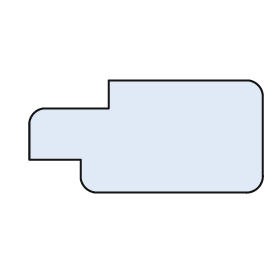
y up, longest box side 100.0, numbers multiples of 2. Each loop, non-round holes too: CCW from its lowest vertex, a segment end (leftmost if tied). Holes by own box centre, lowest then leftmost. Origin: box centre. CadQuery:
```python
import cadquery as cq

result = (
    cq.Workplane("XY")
    .moveTo(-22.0, -24.0)
    .lineTo(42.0, -24.0)
    .threePointArc((48.0, -22.0), (50.0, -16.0))
    .lineTo(50.0, 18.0)
    .threePointArc((48.0, 22.0), (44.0, 24.0))
    .lineTo(-16.0, 24.0)
    .lineTo(-16.0, 12.0)
    .lineTo(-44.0, 12.0)
    .threePointArc((-48.0, 10.0), (-50.0, 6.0))
    .lineTo(-50.0, -10.0)
    .lineTo(-28.0, -10.0)
    .lineTo(-28.0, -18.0)
    .threePointArc((-26.0, -22.0), (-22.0, -24.0))
    .close()
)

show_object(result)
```